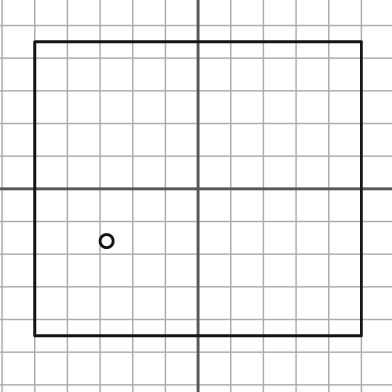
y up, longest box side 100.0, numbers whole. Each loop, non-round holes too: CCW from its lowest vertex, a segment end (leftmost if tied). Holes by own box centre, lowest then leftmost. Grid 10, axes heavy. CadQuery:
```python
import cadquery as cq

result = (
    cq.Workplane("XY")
    .moveTo(-50.0, -45.0)
    .lineTo(50.0, -45.0)
    .lineTo(50.0, 45.0)
    .lineTo(-50.0, 45.0)
    .close()
    .moveTo(-28.0, -16.0)
    .circle(2.0)
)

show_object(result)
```